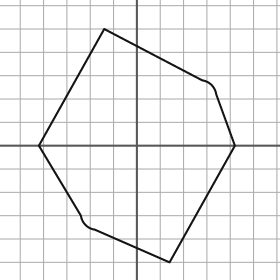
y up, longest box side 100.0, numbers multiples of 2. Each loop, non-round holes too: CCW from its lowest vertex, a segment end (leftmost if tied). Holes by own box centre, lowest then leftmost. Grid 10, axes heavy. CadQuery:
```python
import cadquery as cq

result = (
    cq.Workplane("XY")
    .moveTo(14.0, -50.0)
    .lineTo(42.0, 0.0)
    .lineTo(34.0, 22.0)
    .threePointArc((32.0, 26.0), (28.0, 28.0))
    .lineTo(-14.0, 50.0)
    .lineTo(-42.0, 0.0)
    .lineTo(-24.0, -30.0)
    .threePointArc((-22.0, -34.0), (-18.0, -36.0))
    .close()
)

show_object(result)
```